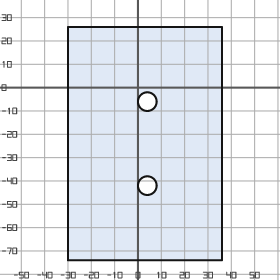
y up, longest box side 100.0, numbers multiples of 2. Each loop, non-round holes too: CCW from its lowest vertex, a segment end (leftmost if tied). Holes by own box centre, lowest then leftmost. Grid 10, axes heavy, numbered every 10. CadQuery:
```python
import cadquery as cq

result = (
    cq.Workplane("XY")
    .moveTo(-30.0, -74.0)
    .lineTo(36.0, -74.0)
    .lineTo(36.0, 26.0)
    .lineTo(-30.0, 26.0)
    .close()
    .moveTo(4.0, -42.0)
    .circle(4.0)
    .moveTo(4.0, -6.0)
    .circle(4.0)
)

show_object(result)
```